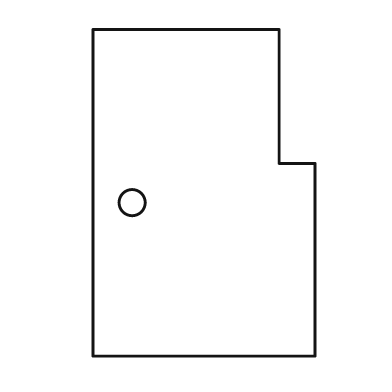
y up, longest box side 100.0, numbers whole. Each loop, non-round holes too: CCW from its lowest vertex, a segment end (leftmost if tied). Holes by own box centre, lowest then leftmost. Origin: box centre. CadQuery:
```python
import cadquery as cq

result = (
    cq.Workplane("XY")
    .moveTo(-34.0, -50.0)
    .lineTo(34.0, -50.0)
    .lineTo(34.0, 9.0)
    .lineTo(23.0, 9.0)
    .lineTo(23.0, 50.0)
    .lineTo(-34.0, 50.0)
    .close()
    .moveTo(-22.0, -3.0)
    .circle(4.0)
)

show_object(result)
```